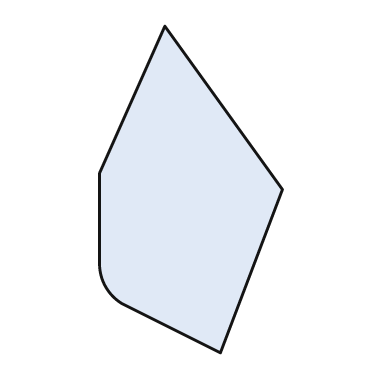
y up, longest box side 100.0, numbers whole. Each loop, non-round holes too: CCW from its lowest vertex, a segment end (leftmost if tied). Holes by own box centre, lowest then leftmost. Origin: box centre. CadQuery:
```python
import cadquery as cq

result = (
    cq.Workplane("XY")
    .moveTo(9.0, -50.0)
    .lineTo(28.0, 0.0)
    .lineTo(-8.0, 50.0)
    .lineTo(-28.0, 5.0)
    .lineTo(-28.0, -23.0)
    .threePointArc((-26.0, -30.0), (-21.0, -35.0))
    .close()
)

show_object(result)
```